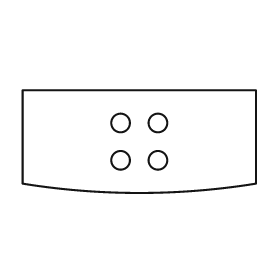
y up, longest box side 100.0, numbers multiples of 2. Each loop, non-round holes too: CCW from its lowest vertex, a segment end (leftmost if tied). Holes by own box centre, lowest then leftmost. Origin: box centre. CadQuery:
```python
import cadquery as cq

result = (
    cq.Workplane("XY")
    .moveTo(-50.0, -18.0)
    .threePointArc((0.0, -22.0), (50.0, -18.0))
    .lineTo(50.0, 22.0)
    .lineTo(-50.0, 22.0)
    .close()
    .moveTo(-8.0, -8.0)
    .circle(4.0)
    .moveTo(8.0, -8.0)
    .circle(4.0)
    .moveTo(-8.0, 8.0)
    .circle(4.0)
    .moveTo(8.0, 8.0)
    .circle(4.0)
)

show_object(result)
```